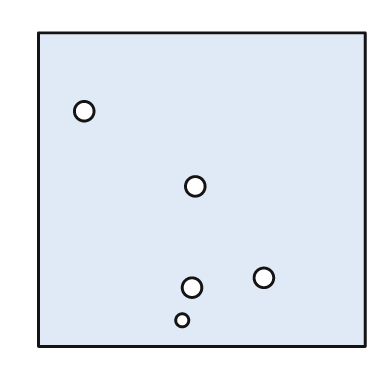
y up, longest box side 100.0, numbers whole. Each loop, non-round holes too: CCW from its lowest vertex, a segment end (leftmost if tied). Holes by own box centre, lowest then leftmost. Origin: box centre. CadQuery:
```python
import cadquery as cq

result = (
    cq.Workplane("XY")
    .moveTo(-50.0, -48.0)
    .lineTo(50.0, -48.0)
    .lineTo(50.0, 48.0)
    .lineTo(-50.0, 48.0)
    .close()
    .moveTo(-6.0, -40.0)
    .circle(2.0)
    .moveTo(-3.0, -30.0)
    .circle(3.0)
    .moveTo(19.0, -27.0)
    .circle(3.0)
    .moveTo(-2.0, 1.0)
    .circle(3.0)
    .moveTo(-36.0, 24.0)
    .circle(3.0)
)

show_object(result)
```